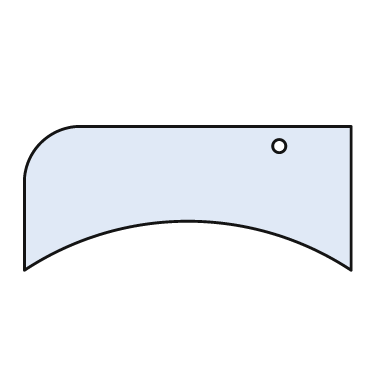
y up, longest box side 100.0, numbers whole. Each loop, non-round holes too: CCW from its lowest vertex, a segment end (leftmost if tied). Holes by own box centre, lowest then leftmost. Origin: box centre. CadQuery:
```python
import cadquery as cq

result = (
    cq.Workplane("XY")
    .moveTo(-50.0, -22.0)
    .threePointArc((0.0, -7.0), (50.0, -22.0))
    .lineTo(50.0, 22.0)
    .lineTo(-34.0, 22.0)
    .threePointArc((-45.0, 17.0), (-50.0, 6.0))
    .close()
    .moveTo(28.0, 16.0)
    .circle(2.0)
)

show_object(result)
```